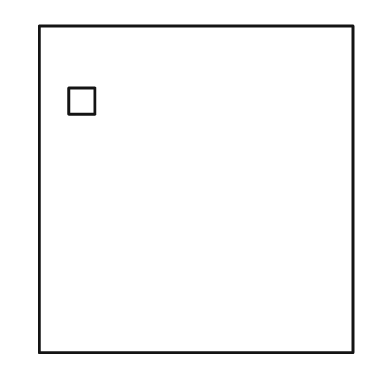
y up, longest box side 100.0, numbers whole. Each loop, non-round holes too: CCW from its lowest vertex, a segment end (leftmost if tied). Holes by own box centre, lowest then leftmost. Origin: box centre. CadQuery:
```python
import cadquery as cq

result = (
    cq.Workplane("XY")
    .moveTo(-48.0, -50.0)
    .lineTo(48.0, -50.0)
    .lineTo(48.0, 50.0)
    .lineTo(-48.0, 50.0)
    .close()
    .moveTo(-39.0, 23.0)
    .lineTo(-31.0, 23.0)
    .lineTo(-31.0, 31.0)
    .lineTo(-39.0, 31.0)
    .close()
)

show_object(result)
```